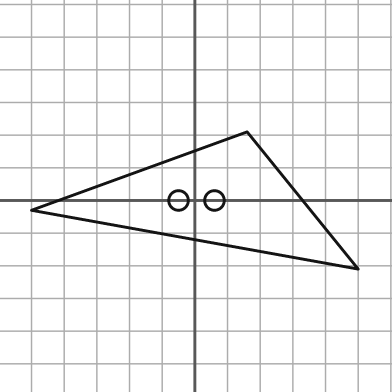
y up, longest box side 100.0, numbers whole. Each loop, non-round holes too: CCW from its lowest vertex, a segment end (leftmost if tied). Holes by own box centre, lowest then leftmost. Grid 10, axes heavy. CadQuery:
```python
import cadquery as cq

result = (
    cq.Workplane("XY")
    .moveTo(50.0, -21.0)
    .lineTo(16.0, 21.0)
    .lineTo(-50.0, -3.0)
    .close()
    .moveTo(-5.0, 0.0)
    .circle(3.0)
    .moveTo(6.0, 0.0)
    .circle(3.0)
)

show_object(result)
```